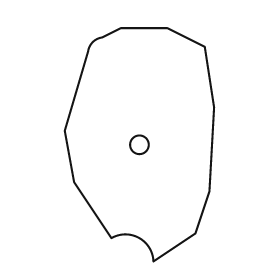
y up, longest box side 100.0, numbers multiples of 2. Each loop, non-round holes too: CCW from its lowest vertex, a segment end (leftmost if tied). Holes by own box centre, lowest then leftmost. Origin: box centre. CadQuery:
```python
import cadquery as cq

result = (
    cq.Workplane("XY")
    .moveTo(6.0, -50.0)
    .lineTo(24.0, -38.0)
    .lineTo(30.0, -20.0)
    .lineTo(32.0, 16.0)
    .lineTo(28.0, 42.0)
    .lineTo(12.0, 50.0)
    .lineTo(-8.0, 50.0)
    .lineTo(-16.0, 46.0)
    .threePointArc((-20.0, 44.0), (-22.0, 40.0))
    .lineTo(-32.0, 6.0)
    .lineTo(-28.0, -16.0)
    .lineTo(-12.0, -40.0)
    .threePointArc((0.0, -40.0), (6.0, -50.0))
    .close()
    .moveTo(0.0, 0.0)
    .circle(4.0)
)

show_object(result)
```